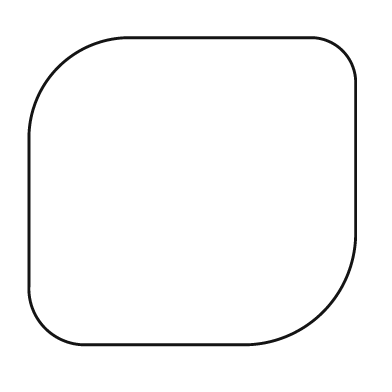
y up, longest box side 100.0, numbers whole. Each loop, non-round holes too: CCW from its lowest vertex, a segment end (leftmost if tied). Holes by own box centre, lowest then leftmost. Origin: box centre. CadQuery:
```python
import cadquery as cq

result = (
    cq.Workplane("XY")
    .moveTo(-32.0, -47.0)
    .lineTo(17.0, -47.0)
    .threePointArc((40.0, -37.0), (50.0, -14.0))
    .lineTo(50.0, 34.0)
    .threePointArc((46.0, 43.0), (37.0, 47.0))
    .lineTo(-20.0, 47.0)
    .threePointArc((-41.0, 38.0), (-50.0, 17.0))
    .lineTo(-50.0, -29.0)
    .threePointArc((-45.0, -42.0), (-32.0, -47.0))
    .close()
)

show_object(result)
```